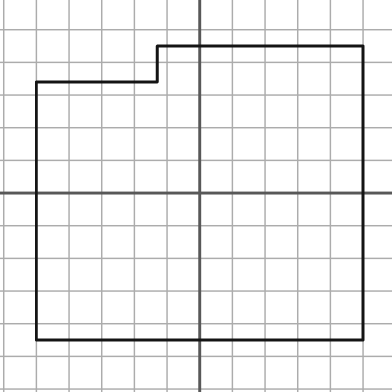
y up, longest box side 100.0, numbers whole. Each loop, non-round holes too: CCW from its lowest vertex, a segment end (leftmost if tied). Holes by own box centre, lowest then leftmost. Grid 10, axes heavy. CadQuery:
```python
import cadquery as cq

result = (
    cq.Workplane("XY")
    .moveTo(-50.0, -45.0)
    .lineTo(50.0, -45.0)
    .lineTo(50.0, 45.0)
    .lineTo(-13.0, 45.0)
    .lineTo(-13.0, 34.0)
    .lineTo(-50.0, 34.0)
    .close()
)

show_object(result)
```